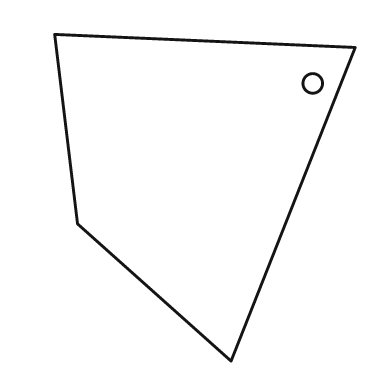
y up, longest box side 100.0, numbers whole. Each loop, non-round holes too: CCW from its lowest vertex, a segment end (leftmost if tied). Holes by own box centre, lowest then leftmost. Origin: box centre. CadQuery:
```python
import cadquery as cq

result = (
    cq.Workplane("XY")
    .moveTo(8.0, -50.0)
    .lineTo(46.0, 46.0)
    .lineTo(-46.0, 50.0)
    .lineTo(-39.0, -8.0)
    .close()
    .moveTo(33.0, 35.0)
    .circle(3.0)
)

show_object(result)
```